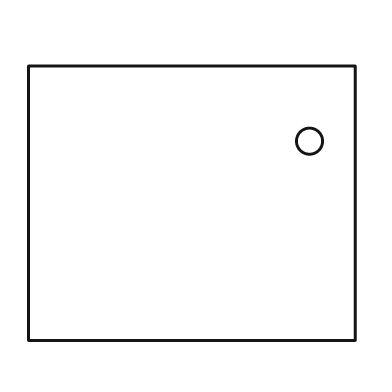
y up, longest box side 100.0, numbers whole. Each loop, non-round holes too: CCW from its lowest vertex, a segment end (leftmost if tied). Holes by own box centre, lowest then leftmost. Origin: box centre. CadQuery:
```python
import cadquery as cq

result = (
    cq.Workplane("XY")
    .moveTo(-50.0, -42.0)
    .lineTo(50.0, -42.0)
    .lineTo(50.0, 42.0)
    .lineTo(-50.0, 42.0)
    .close()
    .moveTo(36.0, 19.0)
    .circle(4.0)
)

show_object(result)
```